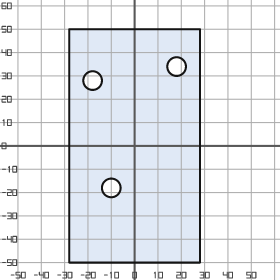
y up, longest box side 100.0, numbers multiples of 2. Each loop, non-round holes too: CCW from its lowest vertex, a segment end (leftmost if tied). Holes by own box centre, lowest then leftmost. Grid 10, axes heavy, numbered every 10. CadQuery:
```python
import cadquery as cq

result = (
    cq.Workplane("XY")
    .moveTo(-28.0, -50.0)
    .lineTo(28.0, -50.0)
    .lineTo(28.0, 50.0)
    .lineTo(-28.0, 50.0)
    .close()
    .moveTo(-10.0, -18.0)
    .circle(4.0)
    .moveTo(-18.0, 28.0)
    .circle(4.0)
    .moveTo(18.0, 34.0)
    .circle(4.0)
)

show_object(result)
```